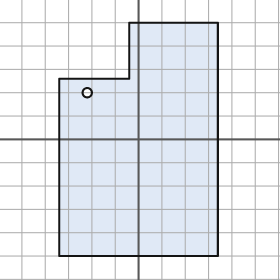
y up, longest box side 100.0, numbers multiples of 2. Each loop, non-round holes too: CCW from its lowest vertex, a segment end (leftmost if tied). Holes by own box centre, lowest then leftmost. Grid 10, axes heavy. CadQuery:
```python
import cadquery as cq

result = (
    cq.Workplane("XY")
    .moveTo(-34.0, -50.0)
    .lineTo(34.0, -50.0)
    .lineTo(34.0, 50.0)
    .lineTo(-4.0, 50.0)
    .lineTo(-4.0, 26.0)
    .lineTo(-34.0, 26.0)
    .close()
    .moveTo(-22.0, 20.0)
    .circle(2.0)
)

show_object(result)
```